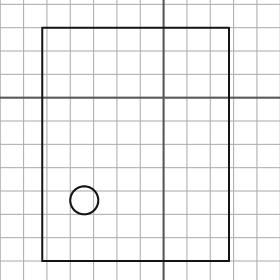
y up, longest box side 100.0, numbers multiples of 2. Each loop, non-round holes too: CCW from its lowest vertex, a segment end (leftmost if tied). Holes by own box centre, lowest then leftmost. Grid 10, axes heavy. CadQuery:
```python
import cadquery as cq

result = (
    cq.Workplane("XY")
    .moveTo(-52.0, -70.0)
    .lineTo(28.0, -70.0)
    .lineTo(28.0, 30.0)
    .lineTo(-52.0, 30.0)
    .close()
    .moveTo(-34.0, -44.0)
    .circle(6.0)
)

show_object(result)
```